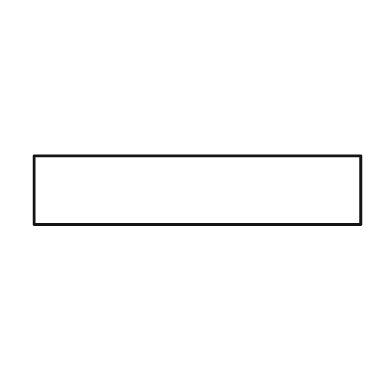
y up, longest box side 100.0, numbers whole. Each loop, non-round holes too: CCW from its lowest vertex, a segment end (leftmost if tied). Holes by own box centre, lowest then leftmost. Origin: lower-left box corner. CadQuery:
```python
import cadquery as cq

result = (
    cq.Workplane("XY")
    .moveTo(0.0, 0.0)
    .lineTo(100.0, 0.0)
    .lineTo(100.0, 21.0)
    .lineTo(0.0, 21.0)
    .close()
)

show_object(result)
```